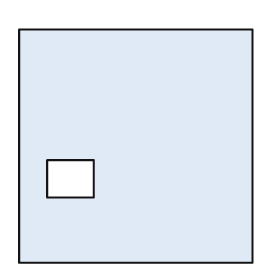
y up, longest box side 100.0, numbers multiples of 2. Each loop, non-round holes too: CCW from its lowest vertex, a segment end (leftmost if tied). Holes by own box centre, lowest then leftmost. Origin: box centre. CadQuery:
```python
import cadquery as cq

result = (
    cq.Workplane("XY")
    .moveTo(-50.0, -50.0)
    .lineTo(50.0, -50.0)
    .lineTo(50.0, 50.0)
    .lineTo(-50.0, 50.0)
    .close()
    .moveTo(-38.0, -22.0)
    .lineTo(-18.0, -22.0)
    .lineTo(-18.0, -6.0)
    .lineTo(-38.0, -6.0)
    .close()
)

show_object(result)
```